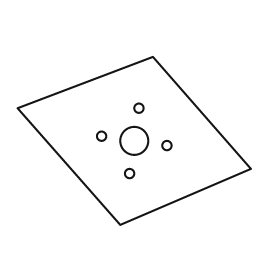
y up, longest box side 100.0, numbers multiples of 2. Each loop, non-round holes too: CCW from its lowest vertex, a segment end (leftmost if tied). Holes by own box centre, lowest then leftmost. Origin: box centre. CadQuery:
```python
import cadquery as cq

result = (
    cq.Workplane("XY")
    .moveTo(-6.0, -36.0)
    .lineTo(50.0, -12.0)
    .lineTo(8.0, 36.0)
    .lineTo(-50.0, 14.0)
    .close()
    .moveTo(-2.0, -14.0)
    .circle(2.0)
    .moveTo(14.0, -2.0)
    .circle(2.0)
    .moveTo(0.0, 0.0)
    .circle(6.0)
    .moveTo(-14.0, 2.0)
    .circle(2.0)
    .moveTo(2.0, 14.0)
    .circle(2.0)
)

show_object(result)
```